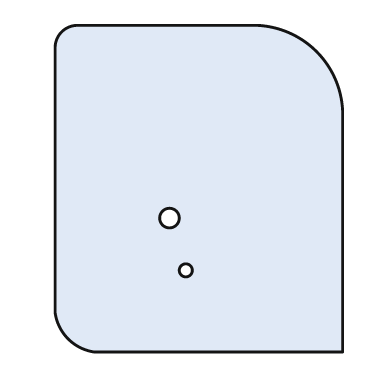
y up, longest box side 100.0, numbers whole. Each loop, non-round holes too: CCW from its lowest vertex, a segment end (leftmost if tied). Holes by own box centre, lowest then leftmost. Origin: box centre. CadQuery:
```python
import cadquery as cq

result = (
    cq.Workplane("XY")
    .moveTo(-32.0, -50.0)
    .lineTo(44.0, -50.0)
    .lineTo(44.0, 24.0)
    .threePointArc((36.0, 42.0), (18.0, 50.0))
    .lineTo(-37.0, 50.0)
    .threePointArc((-42.0, 48.0), (-44.0, 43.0))
    .lineTo(-44.0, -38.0)
    .threePointArc((-40.0, -46.0), (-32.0, -50.0))
    .close()
    .moveTo(-4.0, -25.0)
    .circle(2.0)
    .moveTo(-9.0, -9.0)
    .circle(3.0)
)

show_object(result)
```